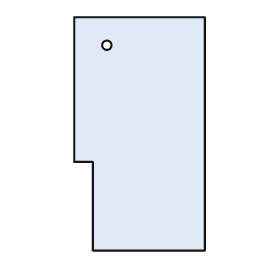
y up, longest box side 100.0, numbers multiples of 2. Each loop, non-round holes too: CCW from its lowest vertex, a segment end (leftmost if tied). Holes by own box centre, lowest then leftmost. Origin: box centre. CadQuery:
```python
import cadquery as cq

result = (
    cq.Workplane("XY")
    .moveTo(-20.0, -50.0)
    .lineTo(28.0, -50.0)
    .lineTo(28.0, 50.0)
    .lineTo(-28.0, 50.0)
    .lineTo(-28.0, -12.0)
    .lineTo(-20.0, -12.0)
    .close()
    .moveTo(-14.0, 38.0)
    .circle(2.0)
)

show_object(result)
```